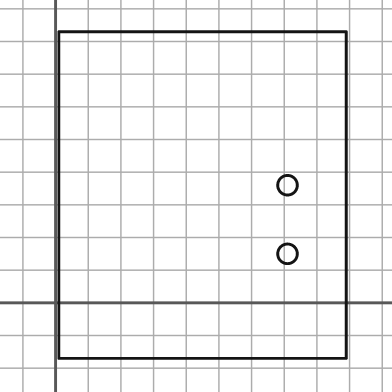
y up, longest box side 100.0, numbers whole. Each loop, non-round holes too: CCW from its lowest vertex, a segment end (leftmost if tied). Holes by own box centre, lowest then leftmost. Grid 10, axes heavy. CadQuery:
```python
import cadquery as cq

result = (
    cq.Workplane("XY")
    .moveTo(1.0, -17.0)
    .lineTo(89.0, -17.0)
    .lineTo(89.0, 83.0)
    .lineTo(1.0, 83.0)
    .close()
    .moveTo(71.0, 15.0)
    .circle(3.0)
    .moveTo(71.0, 36.0)
    .circle(3.0)
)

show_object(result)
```